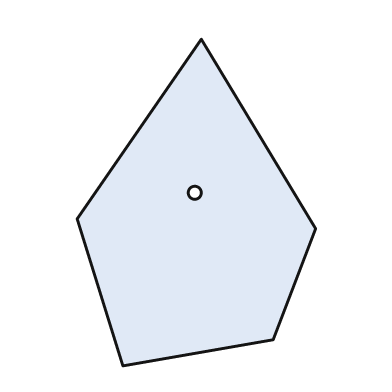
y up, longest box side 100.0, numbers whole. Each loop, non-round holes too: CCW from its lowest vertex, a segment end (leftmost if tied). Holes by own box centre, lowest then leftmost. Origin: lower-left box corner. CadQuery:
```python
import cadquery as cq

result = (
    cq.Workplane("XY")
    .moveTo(14.0, 0.0)
    .lineTo(60.0, 8.0)
    .lineTo(73.0, 42.0)
    .lineTo(38.0, 100.0)
    .lineTo(0.0, 45.0)
    .close()
    .moveTo(36.0, 53.0)
    .circle(2.0)
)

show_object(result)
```